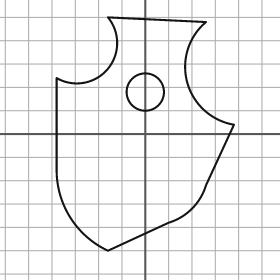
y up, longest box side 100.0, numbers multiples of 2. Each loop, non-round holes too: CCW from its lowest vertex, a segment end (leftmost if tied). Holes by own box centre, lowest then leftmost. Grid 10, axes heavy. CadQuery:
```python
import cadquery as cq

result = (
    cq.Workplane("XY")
    .moveTo(-16.0, -50.0)
    .lineTo(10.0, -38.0)
    .threePointArc((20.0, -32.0), (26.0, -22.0))
    .lineTo(38.0, 4.0)
    .threePointArc((18.0, 22.0), (26.0, 48.0))
    .lineTo(-16.0, 50.0)
    .threePointArc((-16.0, 28.0), (-38.0, 24.0))
    .lineTo(-38.0, -16.0)
    .threePointArc((-32.0, -36.0), (-16.0, -50.0))
    .close()
    .moveTo(0.0, 18.0)
    .circle(8.0)
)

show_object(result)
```